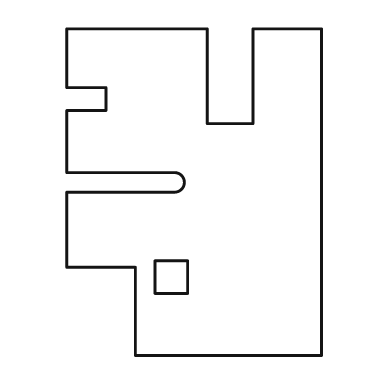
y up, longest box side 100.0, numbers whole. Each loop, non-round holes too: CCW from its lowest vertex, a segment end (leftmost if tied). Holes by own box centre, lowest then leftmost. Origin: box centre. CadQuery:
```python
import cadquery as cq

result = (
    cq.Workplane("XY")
    .moveTo(-18.0, -50.0)
    .lineTo(39.0, -50.0)
    .lineTo(39.0, 50.0)
    .lineTo(18.0, 50.0)
    .lineTo(18.0, 21.0)
    .lineTo(4.0, 21.0)
    .lineTo(4.0, 50.0)
    .lineTo(-39.0, 50.0)
    .lineTo(-39.0, 32.0)
    .lineTo(-27.0, 32.0)
    .lineTo(-27.0, 25.0)
    .lineTo(-39.0, 25.0)
    .lineTo(-39.0, 6.0)
    .lineTo(-6.0, 6.0)
    .threePointArc((-3.0, 3.0), (-6.0, 0.0))
    .lineTo(-39.0, 0.0)
    .lineTo(-39.0, -23.0)
    .lineTo(-18.0, -23.0)
    .close()
    .moveTo(-12.0, -31.0)
    .lineTo(-2.0, -31.0)
    .lineTo(-2.0, -21.0)
    .lineTo(-12.0, -21.0)
    .close()
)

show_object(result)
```